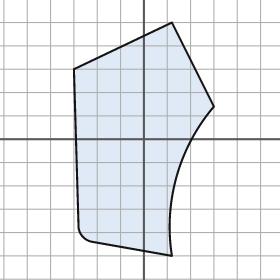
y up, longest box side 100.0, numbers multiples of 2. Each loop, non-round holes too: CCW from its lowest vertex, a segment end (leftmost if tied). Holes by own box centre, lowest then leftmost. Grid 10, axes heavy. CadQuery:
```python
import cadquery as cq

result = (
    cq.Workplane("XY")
    .moveTo(12.0, -50.0)
    .threePointArc((14.0, -16.0), (30.0, 14.0))
    .lineTo(12.0, 50.0)
    .lineTo(-30.0, 30.0)
    .lineTo(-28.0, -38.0)
    .threePointArc((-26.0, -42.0), (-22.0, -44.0))
    .close()
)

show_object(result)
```